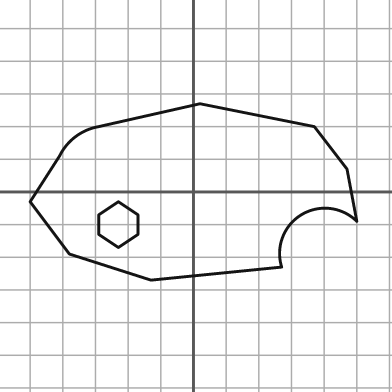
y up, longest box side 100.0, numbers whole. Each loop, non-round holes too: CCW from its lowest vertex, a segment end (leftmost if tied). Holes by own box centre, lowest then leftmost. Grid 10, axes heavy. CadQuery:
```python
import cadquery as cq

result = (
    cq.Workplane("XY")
    .moveTo(-13.0, -27.0)
    .lineTo(27.0, -23.0)
    .threePointArc((33.0, -7.0), (50.0, -9.0))
    .lineTo(47.0, 7.0)
    .lineTo(37.0, 20.0)
    .lineTo(2.0, 27.0)
    .lineTo(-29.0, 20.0)
    .threePointArc((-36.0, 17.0), (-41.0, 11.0))
    .lineTo(-50.0, -3.0)
    .lineTo(-38.0, -19.0)
    .close()
    .moveTo(-23.0, -17.0)
    .lineTo(-17.0, -13.0)
    .lineTo(-17.0, -7.0)
    .lineTo(-23.0, -3.0)
    .lineTo(-29.0, -7.0)
    .lineTo(-29.0, -13.0)
    .close()
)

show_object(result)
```